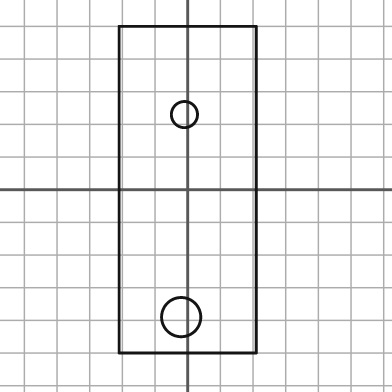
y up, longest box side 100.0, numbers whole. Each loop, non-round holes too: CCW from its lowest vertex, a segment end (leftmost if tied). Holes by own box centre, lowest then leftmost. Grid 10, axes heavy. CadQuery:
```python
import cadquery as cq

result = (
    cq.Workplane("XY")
    .moveTo(-21.0, -50.0)
    .lineTo(21.0, -50.0)
    .lineTo(21.0, 50.0)
    .lineTo(-21.0, 50.0)
    .close()
    .moveTo(-2.0, -39.0)
    .circle(6.0)
    .moveTo(-1.0, 23.0)
    .circle(4.0)
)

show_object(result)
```